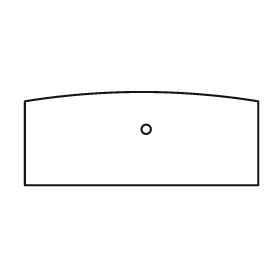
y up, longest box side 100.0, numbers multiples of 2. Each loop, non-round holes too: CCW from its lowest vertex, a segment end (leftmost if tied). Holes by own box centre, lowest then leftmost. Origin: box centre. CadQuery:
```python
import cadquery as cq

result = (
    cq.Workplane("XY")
    .moveTo(-50.0, -20.0)
    .lineTo(50.0, -20.0)
    .lineTo(50.0, 16.0)
    .threePointArc((0.0, 20.0), (-50.0, 16.0))
    .close()
    .moveTo(2.0, 4.0)
    .circle(2.0)
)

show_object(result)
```